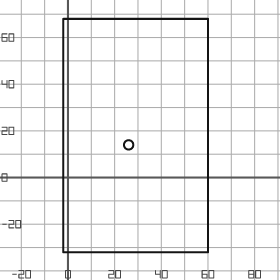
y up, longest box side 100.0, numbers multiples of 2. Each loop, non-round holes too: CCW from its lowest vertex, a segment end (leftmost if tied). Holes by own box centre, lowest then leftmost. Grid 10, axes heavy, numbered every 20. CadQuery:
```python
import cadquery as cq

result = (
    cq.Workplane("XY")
    .moveTo(-2.0, -32.0)
    .lineTo(60.0, -32.0)
    .lineTo(60.0, 68.0)
    .lineTo(-2.0, 68.0)
    .close()
    .moveTo(26.0, 14.0)
    .circle(2.0)
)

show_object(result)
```